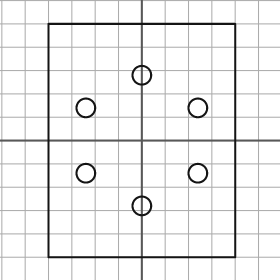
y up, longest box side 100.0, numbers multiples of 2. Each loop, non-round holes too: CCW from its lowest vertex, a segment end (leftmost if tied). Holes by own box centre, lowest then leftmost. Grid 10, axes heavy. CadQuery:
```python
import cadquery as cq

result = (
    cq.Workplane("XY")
    .moveTo(-40.0, -50.0)
    .lineTo(40.0, -50.0)
    .lineTo(40.0, 50.0)
    .lineTo(-40.0, 50.0)
    .close()
    .moveTo(0.0, -28.0)
    .circle(4.0)
    .moveTo(-24.0, -14.0)
    .circle(4.0)
    .moveTo(24.0, -14.0)
    .circle(4.0)
    .moveTo(-24.0, 14.0)
    .circle(4.0)
    .moveTo(24.0, 14.0)
    .circle(4.0)
    .moveTo(0.0, 28.0)
    .circle(4.0)
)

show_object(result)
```